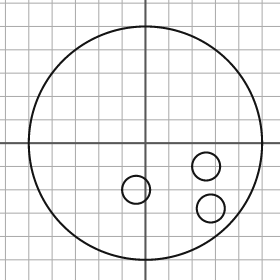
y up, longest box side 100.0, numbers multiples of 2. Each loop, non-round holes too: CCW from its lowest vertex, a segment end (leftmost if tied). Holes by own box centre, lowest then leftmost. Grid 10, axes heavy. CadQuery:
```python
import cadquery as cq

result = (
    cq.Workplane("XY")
    .moveTo(0.0, 0.0)
    .circle(50.0)
    .moveTo(28.0, -28.0)
    .circle(6.0)
    .moveTo(-4.0, -20.0)
    .circle(6.0)
    .moveTo(26.0, -10.0)
    .circle(6.0)
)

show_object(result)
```